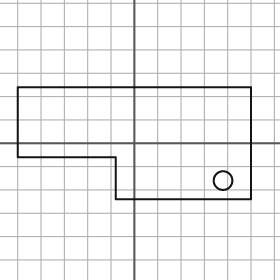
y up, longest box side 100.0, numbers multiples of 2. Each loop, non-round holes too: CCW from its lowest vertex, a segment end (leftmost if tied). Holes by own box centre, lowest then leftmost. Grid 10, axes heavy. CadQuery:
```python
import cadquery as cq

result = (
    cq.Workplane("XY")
    .moveTo(-8.0, -24.0)
    .lineTo(50.0, -24.0)
    .lineTo(50.0, 24.0)
    .lineTo(-50.0, 24.0)
    .lineTo(-50.0, -6.0)
    .lineTo(-8.0, -6.0)
    .close()
    .moveTo(38.0, -16.0)
    .circle(4.0)
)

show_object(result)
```